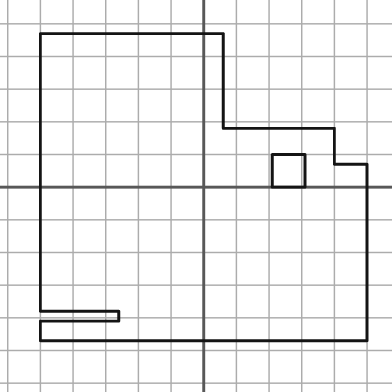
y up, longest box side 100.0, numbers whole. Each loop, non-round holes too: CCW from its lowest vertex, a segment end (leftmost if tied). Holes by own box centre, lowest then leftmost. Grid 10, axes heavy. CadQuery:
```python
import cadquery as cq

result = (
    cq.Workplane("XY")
    .moveTo(-50.0, -47.0)
    .lineTo(50.0, -47.0)
    .lineTo(50.0, 7.0)
    .lineTo(40.0, 7.0)
    .lineTo(40.0, 18.0)
    .lineTo(6.0, 18.0)
    .lineTo(6.0, 47.0)
    .lineTo(-50.0, 47.0)
    .lineTo(-50.0, -38.0)
    .lineTo(-26.0, -38.0)
    .lineTo(-26.0, -41.0)
    .lineTo(-50.0, -41.0)
    .close()
    .moveTo(21.0, 0.0)
    .lineTo(31.0, 0.0)
    .lineTo(31.0, 10.0)
    .lineTo(21.0, 10.0)
    .close()
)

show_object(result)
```